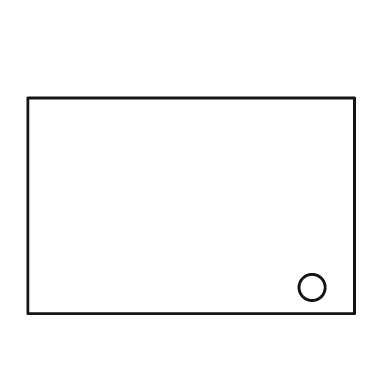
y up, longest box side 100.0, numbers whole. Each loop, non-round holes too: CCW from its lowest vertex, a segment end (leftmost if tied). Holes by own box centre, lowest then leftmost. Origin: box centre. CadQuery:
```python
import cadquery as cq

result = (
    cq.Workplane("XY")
    .moveTo(-50.0, -33.0)
    .lineTo(50.0, -33.0)
    .lineTo(50.0, 33.0)
    .lineTo(-50.0, 33.0)
    .close()
    .moveTo(37.0, -25.0)
    .circle(4.0)
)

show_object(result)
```